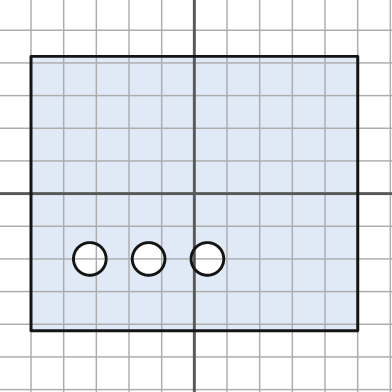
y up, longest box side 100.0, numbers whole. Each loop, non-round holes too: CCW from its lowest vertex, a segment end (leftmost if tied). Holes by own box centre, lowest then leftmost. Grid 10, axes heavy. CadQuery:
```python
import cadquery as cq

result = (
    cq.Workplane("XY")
    .moveTo(-50.0, -42.0)
    .lineTo(50.0, -42.0)
    .lineTo(50.0, 42.0)
    .lineTo(-50.0, 42.0)
    .close()
    .moveTo(-32.0, -20.0)
    .circle(5.0)
    .moveTo(-14.0, -20.0)
    .circle(5.0)
    .moveTo(4.0, -20.0)
    .circle(5.0)
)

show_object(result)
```